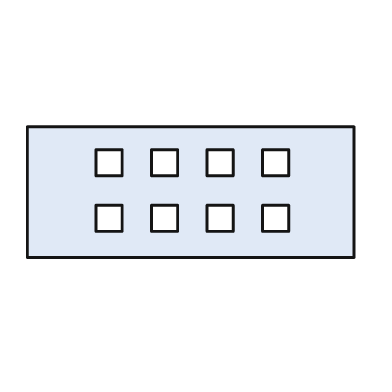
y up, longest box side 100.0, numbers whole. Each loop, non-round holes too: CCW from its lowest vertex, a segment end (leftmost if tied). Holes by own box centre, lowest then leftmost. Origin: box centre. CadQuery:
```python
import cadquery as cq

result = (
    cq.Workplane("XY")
    .moveTo(-50.0, -20.0)
    .lineTo(50.0, -20.0)
    .lineTo(50.0, 20.0)
    .lineTo(-50.0, 20.0)
    .close()
    .moveTo(-29.0, -12.0)
    .lineTo(-21.0, -12.0)
    .lineTo(-21.0, -4.0)
    .lineTo(-29.0, -4.0)
    .close()
    .moveTo(-12.0, -12.0)
    .lineTo(-4.0, -12.0)
    .lineTo(-4.0, -4.0)
    .lineTo(-12.0, -4.0)
    .close()
    .moveTo(5.0, -12.0)
    .lineTo(13.0, -12.0)
    .lineTo(13.0, -4.0)
    .lineTo(5.0, -4.0)
    .close()
    .moveTo(22.0, -12.0)
    .lineTo(30.0, -12.0)
    .lineTo(30.0, -4.0)
    .lineTo(22.0, -4.0)
    .close()
    .moveTo(-29.0, 5.0)
    .lineTo(-21.0, 5.0)
    .lineTo(-21.0, 13.0)
    .lineTo(-29.0, 13.0)
    .close()
    .moveTo(-12.0, 5.0)
    .lineTo(-4.0, 5.0)
    .lineTo(-4.0, 13.0)
    .lineTo(-12.0, 13.0)
    .close()
    .moveTo(5.0, 5.0)
    .lineTo(13.0, 5.0)
    .lineTo(13.0, 13.0)
    .lineTo(5.0, 13.0)
    .close()
    .moveTo(22.0, 5.0)
    .lineTo(30.0, 5.0)
    .lineTo(30.0, 13.0)
    .lineTo(22.0, 13.0)
    .close()
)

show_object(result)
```